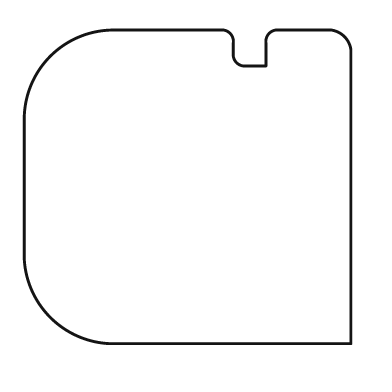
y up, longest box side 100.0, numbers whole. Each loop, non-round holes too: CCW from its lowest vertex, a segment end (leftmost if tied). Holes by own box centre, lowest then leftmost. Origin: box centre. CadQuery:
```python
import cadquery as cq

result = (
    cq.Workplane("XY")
    .moveTo(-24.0, -48.0)
    .lineTo(50.0, -48.0)
    .lineTo(50.0, 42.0)
    .threePointArc((48.0, 46.0), (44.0, 48.0))
    .lineTo(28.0, 48.0)
    .threePointArc((25.0, 47.0), (24.0, 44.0))
    .lineTo(24.0, 37.0)
    .lineTo(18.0, 37.0)
    .threePointArc((15.0, 38.0), (14.0, 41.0))
    .lineTo(14.0, 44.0)
    .threePointArc((13.0, 47.0), (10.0, 48.0))
    .lineTo(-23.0, 48.0)
    .threePointArc((-42.0, 40.0), (-50.0, 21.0))
    .lineTo(-50.0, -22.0)
    .threePointArc((-42.0, -40.0), (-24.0, -48.0))
    .close()
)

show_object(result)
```